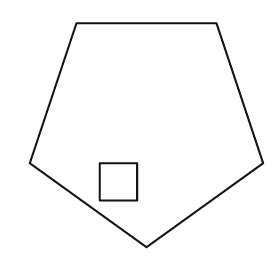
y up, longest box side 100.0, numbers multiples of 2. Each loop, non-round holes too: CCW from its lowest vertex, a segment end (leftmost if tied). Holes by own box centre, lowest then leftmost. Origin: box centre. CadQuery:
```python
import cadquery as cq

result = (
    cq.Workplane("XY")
    .moveTo(0.0, -48.0)
    .lineTo(50.0, -12.0)
    .lineTo(30.0, 48.0)
    .lineTo(-30.0, 48.0)
    .lineTo(-50.0, -12.0)
    .close()
    .moveTo(-20.0, -28.0)
    .lineTo(-4.0, -28.0)
    .lineTo(-4.0, -12.0)
    .lineTo(-20.0, -12.0)
    .close()
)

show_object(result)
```